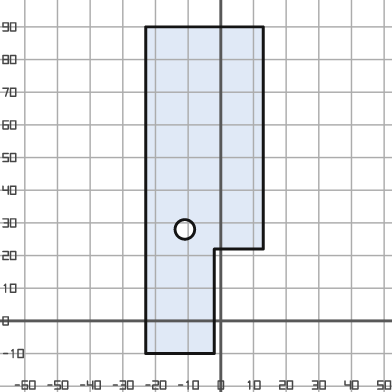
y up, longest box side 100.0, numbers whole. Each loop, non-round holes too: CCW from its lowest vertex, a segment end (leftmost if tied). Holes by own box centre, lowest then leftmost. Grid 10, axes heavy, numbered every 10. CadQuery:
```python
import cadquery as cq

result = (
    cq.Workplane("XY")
    .moveTo(-23.0, -10.0)
    .lineTo(-2.0, -10.0)
    .lineTo(-2.0, 22.0)
    .lineTo(13.0, 22.0)
    .lineTo(13.0, 90.0)
    .lineTo(-23.0, 90.0)
    .close()
    .moveTo(-11.0, 28.0)
    .circle(3.0)
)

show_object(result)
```